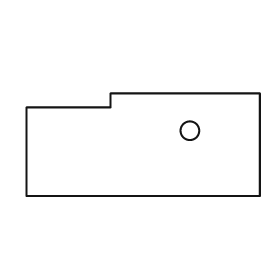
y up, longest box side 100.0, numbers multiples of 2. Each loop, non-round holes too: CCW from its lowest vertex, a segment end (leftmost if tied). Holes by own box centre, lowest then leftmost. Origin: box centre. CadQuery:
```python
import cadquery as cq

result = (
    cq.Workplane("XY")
    .moveTo(-50.0, -22.0)
    .lineTo(50.0, -22.0)
    .lineTo(50.0, 22.0)
    .lineTo(-14.0, 22.0)
    .lineTo(-14.0, 16.0)
    .lineTo(-50.0, 16.0)
    .close()
    .moveTo(20.0, 6.0)
    .circle(4.0)
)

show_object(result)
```